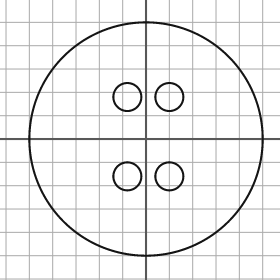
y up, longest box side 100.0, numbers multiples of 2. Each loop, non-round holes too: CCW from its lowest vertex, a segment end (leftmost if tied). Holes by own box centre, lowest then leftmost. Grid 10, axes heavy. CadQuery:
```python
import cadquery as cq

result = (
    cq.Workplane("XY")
    .moveTo(0.0, 0.0)
    .circle(50.0)
    .moveTo(-8.0, -16.0)
    .circle(6.0)
    .moveTo(10.0, -16.0)
    .circle(6.0)
    .moveTo(-8.0, 18.0)
    .circle(6.0)
    .moveTo(10.0, 18.0)
    .circle(6.0)
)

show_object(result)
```